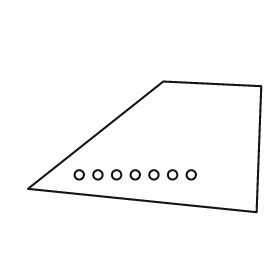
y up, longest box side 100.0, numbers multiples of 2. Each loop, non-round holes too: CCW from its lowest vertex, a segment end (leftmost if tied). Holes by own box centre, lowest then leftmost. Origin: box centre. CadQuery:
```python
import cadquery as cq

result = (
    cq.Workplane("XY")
    .moveTo(48.0, -28.0)
    .lineTo(50.0, 26.0)
    .lineTo(8.0, 28.0)
    .lineTo(-50.0, -18.0)
    .close()
    .moveTo(-28.0, -12.0)
    .circle(2.0)
    .moveTo(-20.0, -12.0)
    .circle(2.0)
    .moveTo(-12.0, -12.0)
    .circle(2.0)
    .moveTo(-4.0, -12.0)
    .circle(2.0)
    .moveTo(4.0, -12.0)
    .circle(2.0)
    .moveTo(12.0, -12.0)
    .circle(2.0)
    .moveTo(20.0, -12.0)
    .circle(2.0)
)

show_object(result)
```